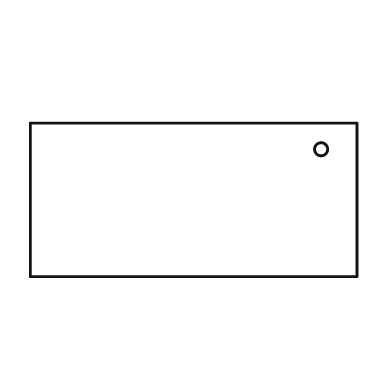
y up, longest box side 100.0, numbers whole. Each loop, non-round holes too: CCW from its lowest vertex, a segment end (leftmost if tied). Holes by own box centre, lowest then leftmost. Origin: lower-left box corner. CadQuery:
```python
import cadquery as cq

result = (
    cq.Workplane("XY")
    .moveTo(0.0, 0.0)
    .lineTo(100.0, 0.0)
    .lineTo(100.0, 47.0)
    .lineTo(0.0, 47.0)
    .close()
    .moveTo(89.0, 39.0)
    .circle(2.0)
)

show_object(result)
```